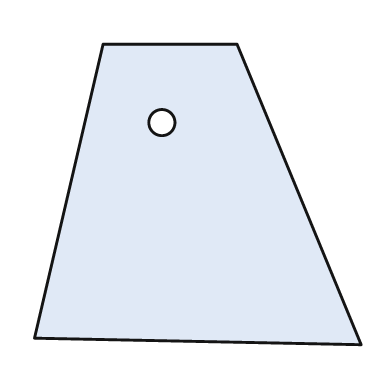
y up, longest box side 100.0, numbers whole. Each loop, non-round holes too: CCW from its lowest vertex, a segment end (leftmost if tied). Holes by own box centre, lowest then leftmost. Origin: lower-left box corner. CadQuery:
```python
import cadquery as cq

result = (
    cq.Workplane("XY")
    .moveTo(100.0, 0.0)
    .lineTo(62.0, 92.0)
    .lineTo(21.0, 92.0)
    .lineTo(0.0, 2.0)
    .close()
    .moveTo(39.0, 68.0)
    .circle(4.0)
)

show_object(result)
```